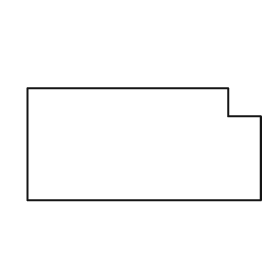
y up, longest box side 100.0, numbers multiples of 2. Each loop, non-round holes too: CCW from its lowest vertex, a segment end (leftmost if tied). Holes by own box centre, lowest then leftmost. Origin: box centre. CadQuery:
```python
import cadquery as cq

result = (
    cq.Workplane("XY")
    .moveTo(-50.0, -24.0)
    .lineTo(50.0, -24.0)
    .lineTo(50.0, 12.0)
    .lineTo(36.0, 12.0)
    .lineTo(36.0, 24.0)
    .lineTo(-50.0, 24.0)
    .close()
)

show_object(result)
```